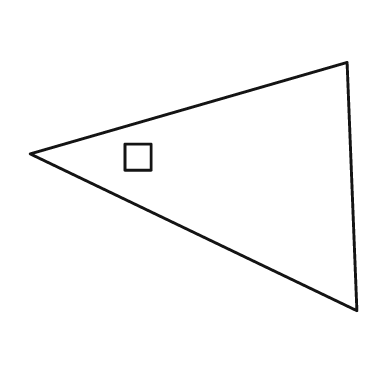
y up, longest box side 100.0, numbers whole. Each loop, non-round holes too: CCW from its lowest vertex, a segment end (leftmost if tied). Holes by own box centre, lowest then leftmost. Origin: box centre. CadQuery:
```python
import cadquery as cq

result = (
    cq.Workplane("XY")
    .moveTo(50.0, -38.0)
    .lineTo(47.0, 38.0)
    .lineTo(-50.0, 10.0)
    .close()
    .moveTo(-21.0, 5.0)
    .lineTo(-13.0, 5.0)
    .lineTo(-13.0, 13.0)
    .lineTo(-21.0, 13.0)
    .close()
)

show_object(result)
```